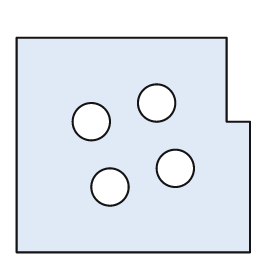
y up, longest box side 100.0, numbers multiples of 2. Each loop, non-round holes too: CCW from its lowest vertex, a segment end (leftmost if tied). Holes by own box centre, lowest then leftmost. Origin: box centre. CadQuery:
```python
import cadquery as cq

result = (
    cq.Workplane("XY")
    .moveTo(-50.0, -46.0)
    .lineTo(50.0, -46.0)
    .lineTo(50.0, 10.0)
    .lineTo(40.0, 10.0)
    .lineTo(40.0, 46.0)
    .lineTo(-50.0, 46.0)
    .close()
    .moveTo(-10.0, -18.0)
    .circle(8.0)
    .moveTo(18.0, -10.0)
    .circle(8.0)
    .moveTo(-18.0, 10.0)
    .circle(8.0)
    .moveTo(10.0, 18.0)
    .circle(8.0)
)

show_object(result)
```